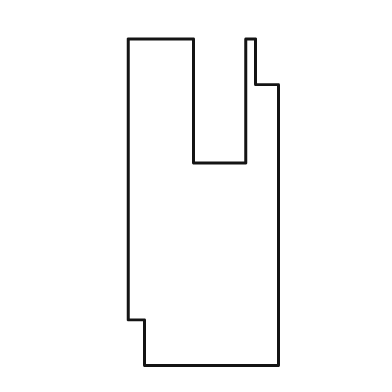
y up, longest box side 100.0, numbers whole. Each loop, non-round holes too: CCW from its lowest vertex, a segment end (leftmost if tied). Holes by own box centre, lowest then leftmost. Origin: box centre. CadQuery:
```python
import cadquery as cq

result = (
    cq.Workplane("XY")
    .moveTo(-18.0, -50.0)
    .lineTo(23.0, -50.0)
    .lineTo(23.0, 36.0)
    .lineTo(16.0, 36.0)
    .lineTo(16.0, 50.0)
    .lineTo(13.0, 50.0)
    .lineTo(13.0, 12.0)
    .lineTo(-3.0, 12.0)
    .lineTo(-3.0, 50.0)
    .lineTo(-23.0, 50.0)
    .lineTo(-23.0, -36.0)
    .lineTo(-18.0, -36.0)
    .close()
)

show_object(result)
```